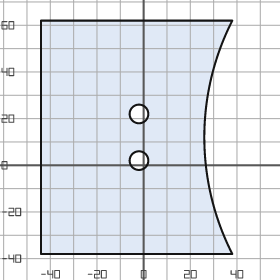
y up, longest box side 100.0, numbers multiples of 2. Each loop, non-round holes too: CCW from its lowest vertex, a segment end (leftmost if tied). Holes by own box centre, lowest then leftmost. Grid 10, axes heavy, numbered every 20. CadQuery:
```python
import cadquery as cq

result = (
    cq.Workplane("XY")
    .moveTo(-44.0, -38.0)
    .lineTo(38.0, -38.0)
    .threePointArc((26.0, 12.0), (38.0, 62.0))
    .lineTo(-44.0, 62.0)
    .close()
    .moveTo(-2.0, 2.0)
    .circle(4.0)
    .moveTo(-2.0, 22.0)
    .circle(4.0)
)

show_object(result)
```